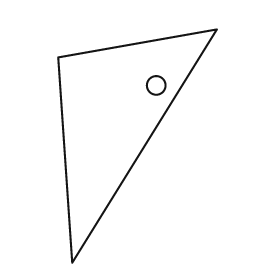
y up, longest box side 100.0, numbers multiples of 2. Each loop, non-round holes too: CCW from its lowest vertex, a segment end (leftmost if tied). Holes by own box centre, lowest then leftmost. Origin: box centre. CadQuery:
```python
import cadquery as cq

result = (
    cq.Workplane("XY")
    .moveTo(-28.0, -50.0)
    .lineTo(34.0, 50.0)
    .lineTo(-34.0, 38.0)
    .close()
    .moveTo(8.0, 26.0)
    .circle(4.0)
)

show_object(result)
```